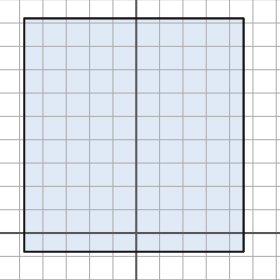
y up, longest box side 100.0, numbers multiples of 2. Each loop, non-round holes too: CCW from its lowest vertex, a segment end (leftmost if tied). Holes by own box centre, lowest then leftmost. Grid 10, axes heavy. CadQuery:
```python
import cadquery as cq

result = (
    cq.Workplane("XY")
    .moveTo(-48.0, -8.0)
    .lineTo(46.0, -8.0)
    .lineTo(46.0, 92.0)
    .lineTo(-48.0, 92.0)
    .close()
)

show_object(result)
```